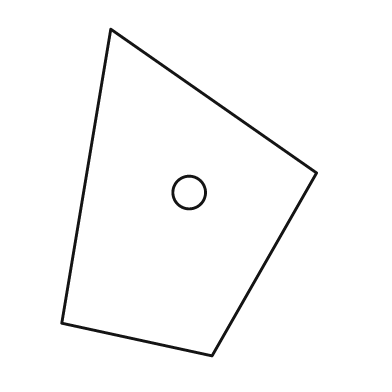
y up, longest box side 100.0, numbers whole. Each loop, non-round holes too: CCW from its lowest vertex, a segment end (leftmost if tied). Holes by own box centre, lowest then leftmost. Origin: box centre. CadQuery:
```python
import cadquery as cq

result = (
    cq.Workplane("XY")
    .moveTo(7.0, -50.0)
    .lineTo(39.0, 6.0)
    .lineTo(-24.0, 50.0)
    .lineTo(-39.0, -40.0)
    .close()
    .moveTo(0.0, 0.0)
    .circle(5.0)
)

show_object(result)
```